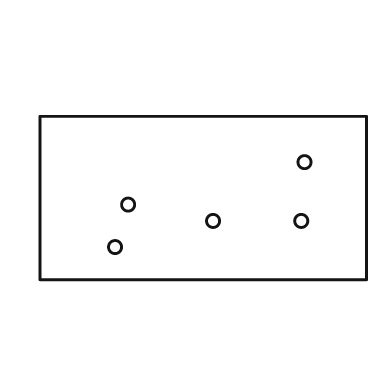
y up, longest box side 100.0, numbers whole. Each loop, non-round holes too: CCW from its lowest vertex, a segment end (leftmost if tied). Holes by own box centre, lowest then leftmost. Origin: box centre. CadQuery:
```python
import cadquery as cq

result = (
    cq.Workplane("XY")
    .moveTo(-50.0, -25.0)
    .lineTo(50.0, -25.0)
    .lineTo(50.0, 25.0)
    .lineTo(-50.0, 25.0)
    .close()
    .moveTo(-27.0, -15.0)
    .circle(2.0)
    .moveTo(3.0, -7.0)
    .circle(2.0)
    .moveTo(30.0, -7.0)
    .circle(2.0)
    .moveTo(-23.0, -2.0)
    .circle(2.0)
    .moveTo(31.0, 11.0)
    .circle(2.0)
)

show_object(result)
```